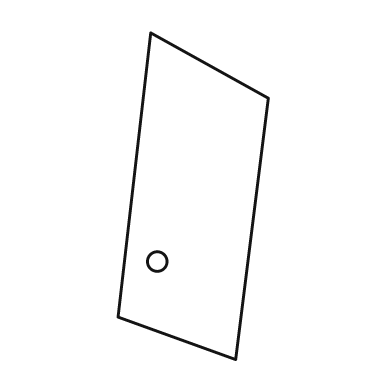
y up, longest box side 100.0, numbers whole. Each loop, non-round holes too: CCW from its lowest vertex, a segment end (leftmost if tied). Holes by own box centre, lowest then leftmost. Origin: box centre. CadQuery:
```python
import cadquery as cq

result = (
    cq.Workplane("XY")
    .moveTo(13.0, -50.0)
    .lineTo(23.0, 30.0)
    .lineTo(-13.0, 50.0)
    .lineTo(-23.0, -37.0)
    .close()
    .moveTo(-11.0, -20.0)
    .circle(3.0)
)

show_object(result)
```